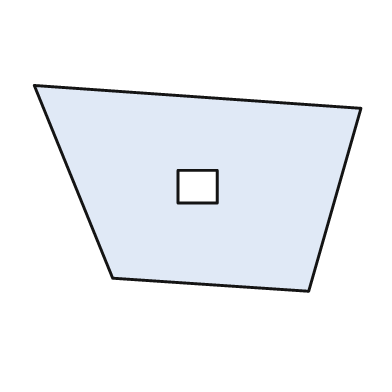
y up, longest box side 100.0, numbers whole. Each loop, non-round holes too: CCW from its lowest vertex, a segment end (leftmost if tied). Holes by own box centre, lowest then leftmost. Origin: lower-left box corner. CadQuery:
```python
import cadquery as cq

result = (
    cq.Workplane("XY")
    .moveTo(84.0, 0.0)
    .lineTo(100.0, 56.0)
    .lineTo(0.0, 63.0)
    .lineTo(24.0, 4.0)
    .close()
    .moveTo(44.0, 27.0)
    .lineTo(56.0, 27.0)
    .lineTo(56.0, 37.0)
    .lineTo(44.0, 37.0)
    .close()
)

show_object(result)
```